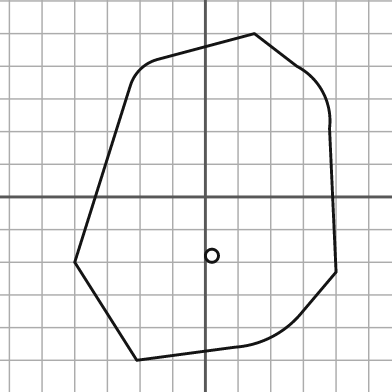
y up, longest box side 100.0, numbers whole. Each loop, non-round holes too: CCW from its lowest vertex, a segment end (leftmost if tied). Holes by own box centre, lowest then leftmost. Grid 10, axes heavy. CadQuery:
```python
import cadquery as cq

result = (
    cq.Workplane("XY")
    .moveTo(-21.0, -50.0)
    .lineTo(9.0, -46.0)
    .threePointArc((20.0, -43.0), (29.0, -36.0))
    .lineTo(40.0, -23.0)
    .lineTo(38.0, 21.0)
    .threePointArc((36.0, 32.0), (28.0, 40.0))
    .lineTo(15.0, 50.0)
    .lineTo(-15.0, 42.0)
    .threePointArc((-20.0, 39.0), (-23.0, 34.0))
    .lineTo(-40.0, -20.0)
    .close()
    .moveTo(2.0, -18.0)
    .circle(2.0)
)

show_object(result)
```